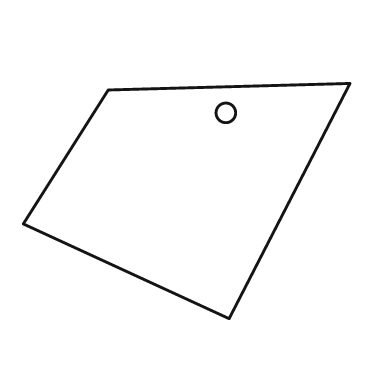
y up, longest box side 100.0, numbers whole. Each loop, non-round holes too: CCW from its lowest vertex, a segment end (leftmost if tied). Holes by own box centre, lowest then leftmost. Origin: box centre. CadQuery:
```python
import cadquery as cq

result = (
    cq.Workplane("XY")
    .moveTo(13.0, -36.0)
    .lineTo(50.0, 36.0)
    .lineTo(-24.0, 34.0)
    .lineTo(-50.0, -7.0)
    .close()
    .moveTo(12.0, 27.0)
    .circle(3.0)
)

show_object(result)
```